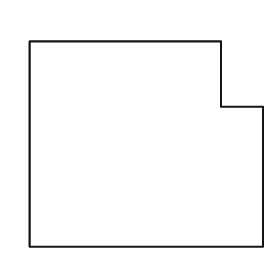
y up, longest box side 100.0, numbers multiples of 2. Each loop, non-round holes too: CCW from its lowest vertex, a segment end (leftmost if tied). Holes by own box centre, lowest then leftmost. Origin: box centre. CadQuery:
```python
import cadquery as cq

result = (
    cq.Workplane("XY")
    .moveTo(-50.0, -44.0)
    .lineTo(50.0, -44.0)
    .lineTo(50.0, 16.0)
    .lineTo(32.0, 16.0)
    .lineTo(32.0, 44.0)
    .lineTo(-50.0, 44.0)
    .close()
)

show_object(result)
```